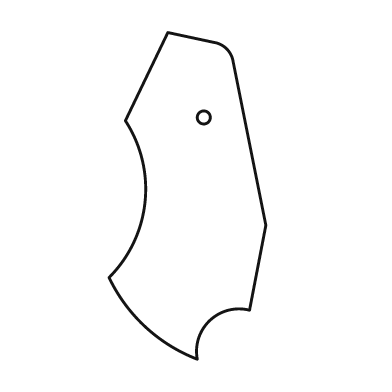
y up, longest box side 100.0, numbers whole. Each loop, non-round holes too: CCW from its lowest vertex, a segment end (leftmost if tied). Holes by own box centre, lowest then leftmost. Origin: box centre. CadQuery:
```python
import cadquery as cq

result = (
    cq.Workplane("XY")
    .moveTo(3.0, -50.0)
    .threePointArc((7.0, -38.0), (19.0, -35.0))
    .lineTo(24.0, -9.0)
    .lineTo(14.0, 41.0)
    .threePointArc((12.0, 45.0), (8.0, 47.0))
    .lineTo(-6.0, 50.0)
    .lineTo(-19.0, 23.0)
    .threePointArc((-13.0, -2.0), (-24.0, -25.0))
    .threePointArc((-13.0, -40.0), (3.0, -50.0))
    .close()
    .moveTo(5.0, 24.0)
    .circle(2.0)
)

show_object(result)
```